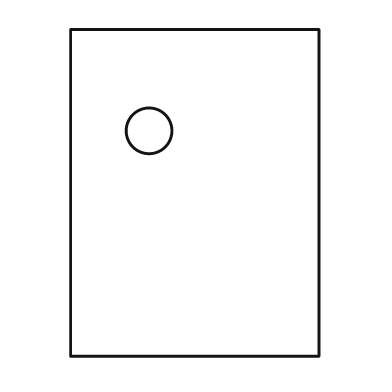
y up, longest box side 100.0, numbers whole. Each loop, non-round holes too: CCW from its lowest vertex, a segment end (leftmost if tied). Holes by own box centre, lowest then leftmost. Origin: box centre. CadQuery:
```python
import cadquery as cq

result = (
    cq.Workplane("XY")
    .moveTo(-38.0, -50.0)
    .lineTo(38.0, -50.0)
    .lineTo(38.0, 50.0)
    .lineTo(-38.0, 50.0)
    .close()
    .moveTo(-14.0, 19.0)
    .circle(7.0)
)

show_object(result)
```